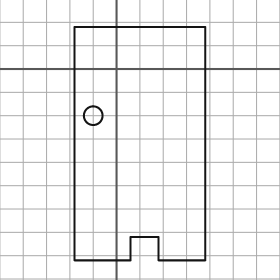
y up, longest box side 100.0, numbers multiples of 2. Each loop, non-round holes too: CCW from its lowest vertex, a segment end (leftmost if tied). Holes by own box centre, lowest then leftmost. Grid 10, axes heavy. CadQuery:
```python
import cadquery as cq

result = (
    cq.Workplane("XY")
    .moveTo(-18.0, -82.0)
    .lineTo(6.0, -82.0)
    .lineTo(6.0, -72.0)
    .lineTo(18.0, -72.0)
    .lineTo(18.0, -82.0)
    .lineTo(38.0, -82.0)
    .lineTo(38.0, 18.0)
    .lineTo(-18.0, 18.0)
    .close()
    .moveTo(-10.0, -20.0)
    .circle(4.0)
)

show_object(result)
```